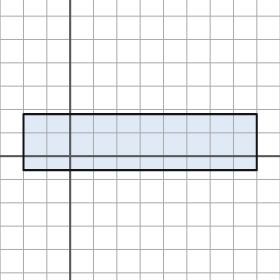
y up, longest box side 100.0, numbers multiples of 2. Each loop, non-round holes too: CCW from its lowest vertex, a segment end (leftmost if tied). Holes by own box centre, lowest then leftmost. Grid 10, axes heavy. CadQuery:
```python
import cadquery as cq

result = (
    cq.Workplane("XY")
    .moveTo(-20.0, -6.0)
    .lineTo(80.0, -6.0)
    .lineTo(80.0, 18.0)
    .lineTo(-20.0, 18.0)
    .close()
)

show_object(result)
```